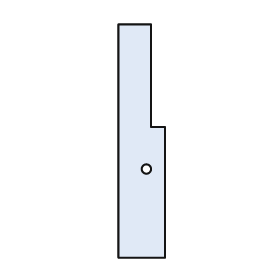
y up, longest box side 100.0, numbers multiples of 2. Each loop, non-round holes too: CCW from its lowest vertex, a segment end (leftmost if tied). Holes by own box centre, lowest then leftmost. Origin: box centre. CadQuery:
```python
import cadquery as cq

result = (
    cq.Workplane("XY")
    .moveTo(-10.0, -50.0)
    .lineTo(10.0, -50.0)
    .lineTo(10.0, 6.0)
    .lineTo(4.0, 6.0)
    .lineTo(4.0, 50.0)
    .lineTo(-10.0, 50.0)
    .close()
    .moveTo(2.0, -12.0)
    .circle(2.0)
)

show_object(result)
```